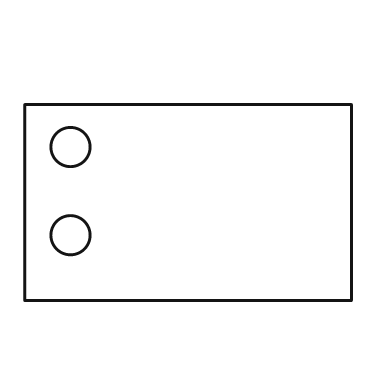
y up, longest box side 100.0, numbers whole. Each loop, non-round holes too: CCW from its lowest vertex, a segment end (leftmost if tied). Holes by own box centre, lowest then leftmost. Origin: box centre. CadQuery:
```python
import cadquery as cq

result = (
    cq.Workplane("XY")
    .moveTo(-50.0, -30.0)
    .lineTo(50.0, -30.0)
    .lineTo(50.0, 30.0)
    .lineTo(-50.0, 30.0)
    .close()
    .moveTo(-36.0, -10.0)
    .circle(6.0)
    .moveTo(-36.0, 17.0)
    .circle(6.0)
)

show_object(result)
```